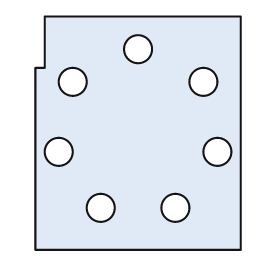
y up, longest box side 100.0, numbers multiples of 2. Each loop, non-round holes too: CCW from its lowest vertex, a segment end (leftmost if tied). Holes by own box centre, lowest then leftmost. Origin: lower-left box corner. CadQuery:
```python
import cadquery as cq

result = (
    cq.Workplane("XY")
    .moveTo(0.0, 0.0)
    .lineTo(88.0, 0.0)
    .lineTo(88.0, 100.0)
    .lineTo(4.0, 100.0)
    .lineTo(4.0, 78.0)
    .lineTo(0.0, 78.0)
    .close()
    .moveTo(28.0, 18.0)
    .circle(6.0)
    .moveTo(60.0, 18.0)
    .circle(6.0)
    .moveTo(10.0, 42.0)
    .circle(6.0)
    .moveTo(78.0, 42.0)
    .circle(6.0)
    .moveTo(16.0, 72.0)
    .circle(6.0)
    .moveTo(72.0, 72.0)
    .circle(6.0)
    .moveTo(44.0, 86.0)
    .circle(6.0)
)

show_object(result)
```